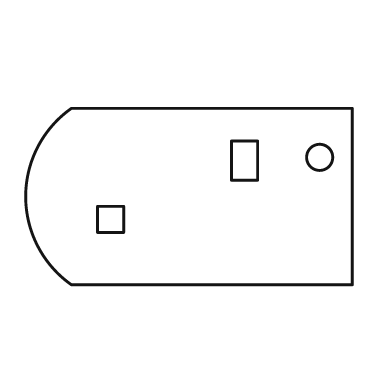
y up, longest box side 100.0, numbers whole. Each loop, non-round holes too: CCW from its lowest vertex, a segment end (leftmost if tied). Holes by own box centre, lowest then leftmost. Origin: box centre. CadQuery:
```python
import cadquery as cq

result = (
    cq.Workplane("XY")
    .moveTo(-36.0, -27.0)
    .lineTo(50.0, -27.0)
    .lineTo(50.0, 27.0)
    .lineTo(-36.0, 27.0)
    .threePointArc((-50.0, 0.0), (-36.0, -27.0))
    .close()
    .moveTo(-28.0, -11.0)
    .lineTo(-20.0, -11.0)
    .lineTo(-20.0, -3.0)
    .lineTo(-28.0, -3.0)
    .close()
    .moveTo(13.0, 5.0)
    .lineTo(21.0, 5.0)
    .lineTo(21.0, 17.0)
    .lineTo(13.0, 17.0)
    .close()
    .moveTo(40.0, 12.0)
    .circle(4.0)
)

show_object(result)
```